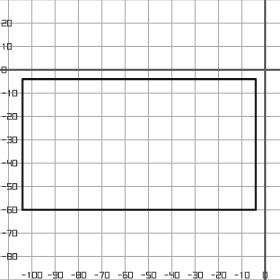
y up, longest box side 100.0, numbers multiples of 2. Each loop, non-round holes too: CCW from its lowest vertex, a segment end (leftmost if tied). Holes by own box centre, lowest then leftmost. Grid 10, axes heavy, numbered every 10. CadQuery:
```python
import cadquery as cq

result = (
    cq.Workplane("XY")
    .moveTo(-104.0, -60.0)
    .lineTo(-4.0, -60.0)
    .lineTo(-4.0, -4.0)
    .lineTo(-104.0, -4.0)
    .close()
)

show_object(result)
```